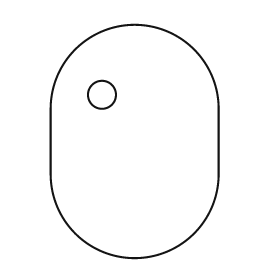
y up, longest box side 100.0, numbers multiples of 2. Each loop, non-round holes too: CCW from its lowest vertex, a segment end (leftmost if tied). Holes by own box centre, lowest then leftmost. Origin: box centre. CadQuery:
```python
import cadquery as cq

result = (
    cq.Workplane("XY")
    .moveTo(-36.0, -14.0)
    .threePointArc((0.0, -50.0), (36.0, -14.0))
    .lineTo(36.0, 14.0)
    .threePointArc((0.0, 50.0), (-36.0, 14.0))
    .close()
    .moveTo(-14.0, 20.0)
    .circle(6.0)
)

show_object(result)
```